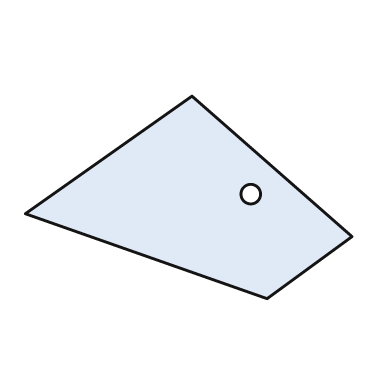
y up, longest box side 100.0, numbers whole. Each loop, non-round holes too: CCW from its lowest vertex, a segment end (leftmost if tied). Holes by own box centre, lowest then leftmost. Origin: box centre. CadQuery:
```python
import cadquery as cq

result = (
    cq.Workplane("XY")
    .moveTo(24.0, -31.0)
    .lineTo(50.0, -12.0)
    .lineTo(1.0, 31.0)
    .lineTo(-50.0, -5.0)
    .close()
    .moveTo(19.0, 1.0)
    .circle(3.0)
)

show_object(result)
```